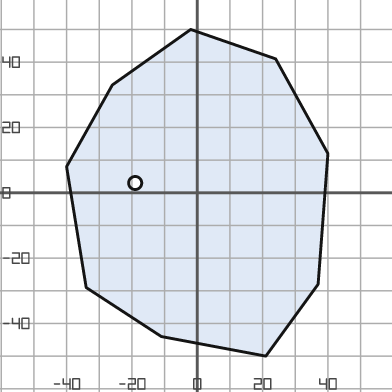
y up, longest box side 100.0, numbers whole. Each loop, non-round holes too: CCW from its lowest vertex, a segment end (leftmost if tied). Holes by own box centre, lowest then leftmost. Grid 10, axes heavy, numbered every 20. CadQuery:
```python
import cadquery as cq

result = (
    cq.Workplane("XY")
    .moveTo(21.0, -50.0)
    .lineTo(37.0, -28.0)
    .lineTo(40.0, 12.0)
    .lineTo(24.0, 41.0)
    .lineTo(-2.0, 50.0)
    .lineTo(-26.0, 33.0)
    .lineTo(-40.0, 8.0)
    .lineTo(-34.0, -29.0)
    .lineTo(-11.0, -44.0)
    .close()
    .moveTo(-19.0, 3.0)
    .circle(2.0)
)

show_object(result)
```